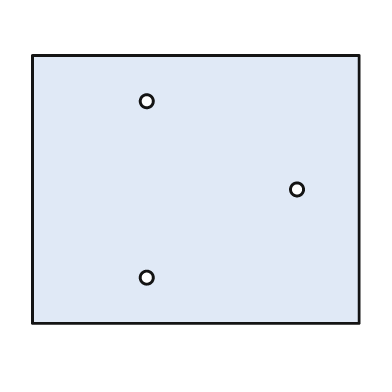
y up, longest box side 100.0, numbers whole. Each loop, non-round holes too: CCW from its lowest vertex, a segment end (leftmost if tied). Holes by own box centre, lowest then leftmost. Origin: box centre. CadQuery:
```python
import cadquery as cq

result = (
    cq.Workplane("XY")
    .moveTo(-50.0, -41.0)
    .lineTo(50.0, -41.0)
    .lineTo(50.0, 41.0)
    .lineTo(-50.0, 41.0)
    .close()
    .moveTo(-15.0, -27.0)
    .circle(2.0)
    .moveTo(31.0, 0.0)
    .circle(2.0)
    .moveTo(-15.0, 27.0)
    .circle(2.0)
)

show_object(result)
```